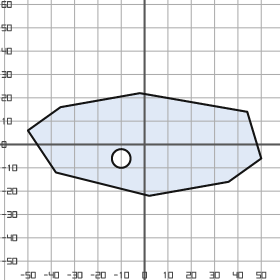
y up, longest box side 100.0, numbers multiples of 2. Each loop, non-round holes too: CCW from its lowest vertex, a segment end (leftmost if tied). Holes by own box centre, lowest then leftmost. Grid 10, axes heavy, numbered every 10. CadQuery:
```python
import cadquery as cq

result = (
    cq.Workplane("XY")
    .moveTo(2.0, -22.0)
    .lineTo(36.0, -16.0)
    .lineTo(50.0, -6.0)
    .lineTo(44.0, 14.0)
    .lineTo(-2.0, 22.0)
    .lineTo(-36.0, 16.0)
    .lineTo(-50.0, 6.0)
    .lineTo(-38.0, -12.0)
    .close()
    .moveTo(-10.0, -6.0)
    .circle(4.0)
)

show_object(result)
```